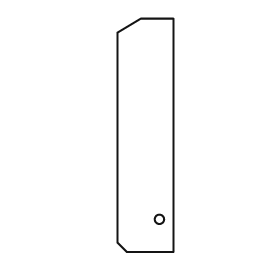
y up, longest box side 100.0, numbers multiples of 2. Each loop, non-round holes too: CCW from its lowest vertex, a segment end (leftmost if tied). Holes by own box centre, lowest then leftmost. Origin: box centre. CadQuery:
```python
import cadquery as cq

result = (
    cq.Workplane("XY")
    .moveTo(-8.0, -50.0)
    .lineTo(12.0, -50.0)
    .lineTo(12.0, 50.0)
    .lineTo(-2.0, 50.0)
    .lineTo(-12.0, 44.0)
    .lineTo(-12.0, -46.0)
    .close()
    .moveTo(6.0, -36.0)
    .circle(2.0)
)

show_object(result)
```